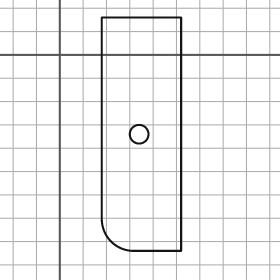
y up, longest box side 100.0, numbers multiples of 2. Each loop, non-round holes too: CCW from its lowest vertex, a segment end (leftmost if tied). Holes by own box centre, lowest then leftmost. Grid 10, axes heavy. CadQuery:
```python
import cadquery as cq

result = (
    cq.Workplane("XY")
    .moveTo(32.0, -84.0)
    .lineTo(52.0, -84.0)
    .lineTo(52.0, 16.0)
    .lineTo(18.0, 16.0)
    .lineTo(18.0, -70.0)
    .threePointArc((22.0, -80.0), (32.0, -84.0))
    .close()
    .moveTo(34.0, -34.0)
    .circle(4.0)
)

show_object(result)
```